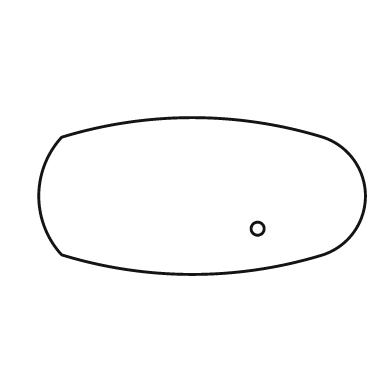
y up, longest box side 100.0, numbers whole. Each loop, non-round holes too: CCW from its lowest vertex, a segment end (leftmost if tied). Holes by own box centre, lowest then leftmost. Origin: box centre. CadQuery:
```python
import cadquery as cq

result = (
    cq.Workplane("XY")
    .moveTo(-43.0, -18.0)
    .threePointArc((-3.0, -24.0), (37.0, -18.0))
    .threePointArc((50.0, 0.0), (37.0, 18.0))
    .threePointArc((-3.0, 24.0), (-43.0, 18.0))
    .threePointArc((-50.0, 0.0), (-43.0, -18.0))
    .close()
    .moveTo(17.0, -10.0)
    .circle(2.0)
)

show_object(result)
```